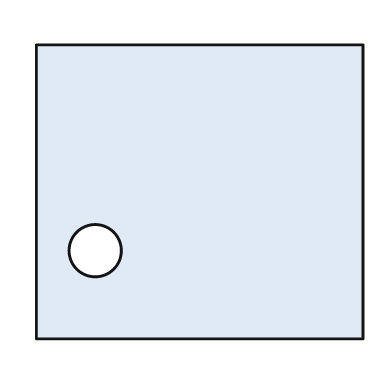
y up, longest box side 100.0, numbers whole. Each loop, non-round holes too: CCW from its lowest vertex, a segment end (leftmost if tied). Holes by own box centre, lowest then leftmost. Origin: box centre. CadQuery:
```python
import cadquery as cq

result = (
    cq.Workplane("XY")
    .moveTo(-50.0, -45.0)
    .lineTo(50.0, -45.0)
    .lineTo(50.0, 45.0)
    .lineTo(-50.0, 45.0)
    .close()
    .moveTo(-32.0, -18.0)
    .circle(8.0)
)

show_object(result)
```